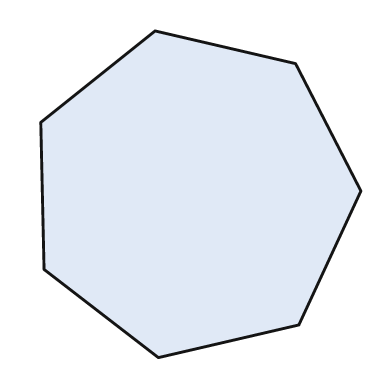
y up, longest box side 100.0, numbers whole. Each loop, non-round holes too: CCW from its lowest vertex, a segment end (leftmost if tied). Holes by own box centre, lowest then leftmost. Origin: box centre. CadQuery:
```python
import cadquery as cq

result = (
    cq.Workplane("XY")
    .moveTo(-13.0, -50.0)
    .lineTo(30.0, -40.0)
    .lineTo(49.0, 1.0)
    .lineTo(29.0, 40.0)
    .lineTo(-14.0, 50.0)
    .lineTo(-49.0, 22.0)
    .lineTo(-48.0, -23.0)
    .close()
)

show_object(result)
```